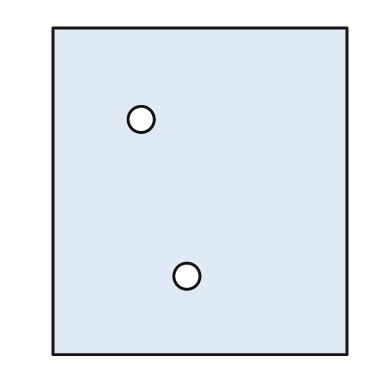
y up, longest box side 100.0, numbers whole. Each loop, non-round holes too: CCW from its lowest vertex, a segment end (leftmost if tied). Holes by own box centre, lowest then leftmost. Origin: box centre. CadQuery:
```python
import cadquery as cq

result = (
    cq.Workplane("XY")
    .moveTo(-45.0, -50.0)
    .lineTo(45.0, -50.0)
    .lineTo(45.0, 50.0)
    .lineTo(-45.0, 50.0)
    .close()
    .moveTo(-4.0, -26.0)
    .circle(4.0)
    .moveTo(-18.0, 22.0)
    .circle(4.0)
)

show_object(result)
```